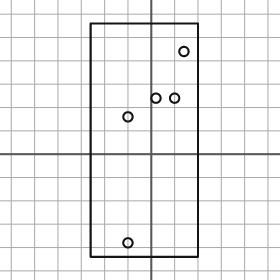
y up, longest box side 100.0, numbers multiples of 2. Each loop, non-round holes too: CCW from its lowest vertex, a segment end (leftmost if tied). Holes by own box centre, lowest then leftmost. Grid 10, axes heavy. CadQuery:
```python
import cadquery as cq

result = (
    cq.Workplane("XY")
    .moveTo(-26.0, -44.0)
    .lineTo(20.0, -44.0)
    .lineTo(20.0, 56.0)
    .lineTo(-26.0, 56.0)
    .close()
    .moveTo(-10.0, -38.0)
    .circle(2.0)
    .moveTo(-10.0, 16.0)
    .circle(2.0)
    .moveTo(2.0, 24.0)
    .circle(2.0)
    .moveTo(10.0, 24.0)
    .circle(2.0)
    .moveTo(14.0, 44.0)
    .circle(2.0)
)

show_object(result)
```